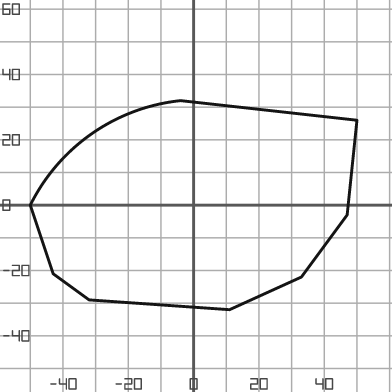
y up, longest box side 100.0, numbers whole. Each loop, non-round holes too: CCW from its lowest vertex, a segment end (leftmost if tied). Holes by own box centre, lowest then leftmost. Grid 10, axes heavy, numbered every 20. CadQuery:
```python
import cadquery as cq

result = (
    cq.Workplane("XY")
    .moveTo(11.0, -32.0)
    .lineTo(33.0, -22.0)
    .lineTo(47.0, -3.0)
    .lineTo(50.0, 26.0)
    .lineTo(-4.0, 32.0)
    .threePointArc((-31.0, 22.0), (-50.0, 0.0))
    .lineTo(-43.0, -21.0)
    .lineTo(-32.0, -29.0)
    .close()
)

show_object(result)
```